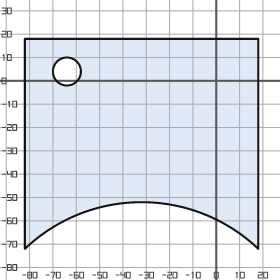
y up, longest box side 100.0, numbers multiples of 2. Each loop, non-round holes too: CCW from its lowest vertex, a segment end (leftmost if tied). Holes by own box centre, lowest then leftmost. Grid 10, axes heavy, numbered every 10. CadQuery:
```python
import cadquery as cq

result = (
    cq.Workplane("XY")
    .moveTo(-82.0, -72.0)
    .threePointArc((-32.0, -52.0), (18.0, -72.0))
    .lineTo(18.0, 18.0)
    .lineTo(-82.0, 18.0)
    .close()
    .moveTo(-64.0, 4.0)
    .circle(6.0)
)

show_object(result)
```